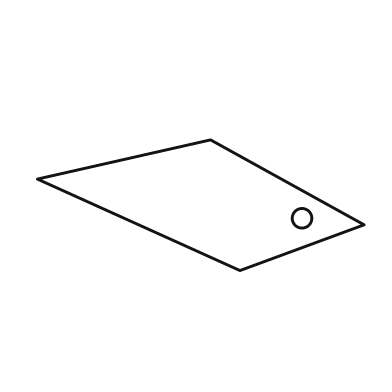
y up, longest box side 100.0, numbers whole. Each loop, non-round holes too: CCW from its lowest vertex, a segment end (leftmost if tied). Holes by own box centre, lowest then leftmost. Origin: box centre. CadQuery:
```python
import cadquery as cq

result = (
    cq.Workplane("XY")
    .moveTo(12.0, -20.0)
    .lineTo(50.0, -6.0)
    .lineTo(3.0, 20.0)
    .lineTo(-50.0, 8.0)
    .close()
    .moveTo(31.0, -4.0)
    .circle(3.0)
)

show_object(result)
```